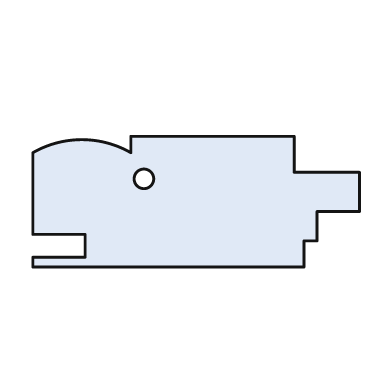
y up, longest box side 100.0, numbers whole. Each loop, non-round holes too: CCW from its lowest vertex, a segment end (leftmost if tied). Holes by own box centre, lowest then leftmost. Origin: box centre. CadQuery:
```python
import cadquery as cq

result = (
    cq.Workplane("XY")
    .moveTo(-50.0, -20.0)
    .lineTo(33.0, -20.0)
    .lineTo(33.0, -12.0)
    .lineTo(37.0, -12.0)
    .lineTo(37.0, -3.0)
    .lineTo(50.0, -3.0)
    .lineTo(50.0, 9.0)
    .lineTo(30.0, 9.0)
    .lineTo(30.0, 20.0)
    .lineTo(-20.0, 20.0)
    .lineTo(-20.0, 15.0)
    .threePointArc((-35.0, 19.0), (-50.0, 15.0))
    .lineTo(-50.0, -10.0)
    .lineTo(-34.0, -10.0)
    .lineTo(-34.0, -17.0)
    .lineTo(-50.0, -17.0)
    .close()
    .moveTo(-16.0, 7.0)
    .circle(3.0)
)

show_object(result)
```